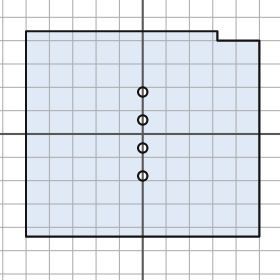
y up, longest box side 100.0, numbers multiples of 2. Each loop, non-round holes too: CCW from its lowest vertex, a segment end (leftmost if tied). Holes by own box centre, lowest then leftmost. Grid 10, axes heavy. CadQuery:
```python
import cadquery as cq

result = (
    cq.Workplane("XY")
    .moveTo(-50.0, -44.0)
    .lineTo(50.0, -44.0)
    .lineTo(50.0, 40.0)
    .lineTo(32.0, 40.0)
    .lineTo(32.0, 44.0)
    .lineTo(-50.0, 44.0)
    .close()
    .moveTo(0.0, -18.0)
    .circle(2.0)
    .moveTo(0.0, -6.0)
    .circle(2.0)
    .moveTo(0.0, 6.0)
    .circle(2.0)
    .moveTo(0.0, 18.0)
    .circle(2.0)
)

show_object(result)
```